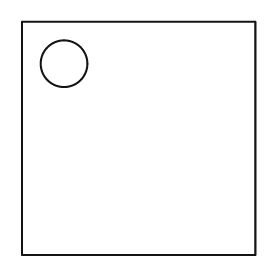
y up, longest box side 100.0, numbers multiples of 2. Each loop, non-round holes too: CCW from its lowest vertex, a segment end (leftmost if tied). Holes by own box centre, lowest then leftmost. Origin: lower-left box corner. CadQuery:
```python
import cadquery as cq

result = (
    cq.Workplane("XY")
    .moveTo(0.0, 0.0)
    .lineTo(100.0, 0.0)
    .lineTo(100.0, 100.0)
    .lineTo(0.0, 100.0)
    .close()
    .moveTo(18.0, 82.0)
    .circle(10.0)
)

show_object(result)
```